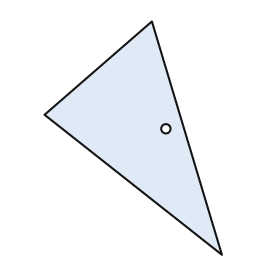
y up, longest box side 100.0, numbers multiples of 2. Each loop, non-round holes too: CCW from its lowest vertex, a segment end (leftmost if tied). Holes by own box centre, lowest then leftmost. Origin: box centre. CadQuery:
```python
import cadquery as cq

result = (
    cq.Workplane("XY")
    .moveTo(38.0, -50.0)
    .lineTo(8.0, 50.0)
    .lineTo(-38.0, 10.0)
    .close()
    .moveTo(14.0, 4.0)
    .circle(2.0)
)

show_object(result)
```